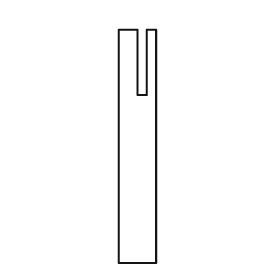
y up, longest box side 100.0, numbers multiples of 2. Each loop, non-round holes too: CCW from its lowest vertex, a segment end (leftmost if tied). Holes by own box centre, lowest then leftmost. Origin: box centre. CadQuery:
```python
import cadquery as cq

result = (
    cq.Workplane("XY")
    .moveTo(-8.0, -50.0)
    .lineTo(8.0, -50.0)
    .lineTo(8.0, 50.0)
    .lineTo(4.0, 50.0)
    .lineTo(4.0, 22.0)
    .lineTo(0.0, 22.0)
    .lineTo(0.0, 50.0)
    .lineTo(-8.0, 50.0)
    .close()
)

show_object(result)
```